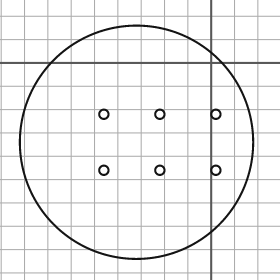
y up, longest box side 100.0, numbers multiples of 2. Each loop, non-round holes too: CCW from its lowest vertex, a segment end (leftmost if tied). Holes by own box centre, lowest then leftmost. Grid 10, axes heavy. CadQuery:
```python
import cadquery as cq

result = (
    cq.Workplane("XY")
    .moveTo(-32.0, -34.0)
    .circle(50.0)
    .moveTo(-46.0, -46.0)
    .circle(2.0)
    .moveTo(-22.0, -46.0)
    .circle(2.0)
    .moveTo(2.0, -46.0)
    .circle(2.0)
    .moveTo(-46.0, -22.0)
    .circle(2.0)
    .moveTo(-22.0, -22.0)
    .circle(2.0)
    .moveTo(2.0, -22.0)
    .circle(2.0)
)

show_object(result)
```